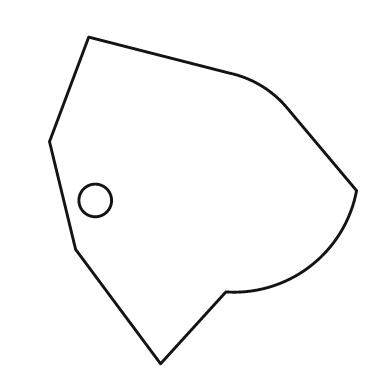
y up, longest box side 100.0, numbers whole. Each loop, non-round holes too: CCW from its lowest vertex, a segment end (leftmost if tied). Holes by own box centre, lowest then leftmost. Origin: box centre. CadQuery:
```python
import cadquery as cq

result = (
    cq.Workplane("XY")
    .moveTo(-13.0, -50.0)
    .lineTo(7.0, -28.0)
    .threePointArc((33.0, -20.0), (47.0, 3.0))
    .lineTo(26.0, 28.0)
    .threePointArc((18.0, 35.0), (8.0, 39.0))
    .lineTo(-35.0, 50.0)
    .lineTo(-47.0, 18.0)
    .lineTo(-39.0, -15.0)
    .close()
    .moveTo(-33.0, 0.0)
    .circle(5.0)
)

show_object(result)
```